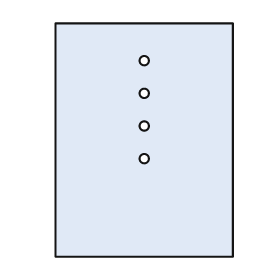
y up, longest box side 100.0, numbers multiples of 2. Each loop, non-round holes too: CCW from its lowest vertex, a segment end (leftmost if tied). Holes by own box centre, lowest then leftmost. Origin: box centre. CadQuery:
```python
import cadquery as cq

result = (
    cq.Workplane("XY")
    .moveTo(-38.0, -50.0)
    .lineTo(38.0, -50.0)
    .lineTo(38.0, 50.0)
    .lineTo(-38.0, 50.0)
    .close()
    .moveTo(0.0, -8.0)
    .circle(2.0)
    .moveTo(0.0, 6.0)
    .circle(2.0)
    .moveTo(0.0, 20.0)
    .circle(2.0)
    .moveTo(0.0, 34.0)
    .circle(2.0)
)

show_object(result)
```